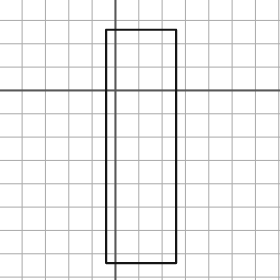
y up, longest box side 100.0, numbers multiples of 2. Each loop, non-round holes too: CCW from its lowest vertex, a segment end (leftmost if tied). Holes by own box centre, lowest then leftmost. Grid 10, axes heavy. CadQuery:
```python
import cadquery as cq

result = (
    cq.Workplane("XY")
    .moveTo(-4.0, -74.0)
    .lineTo(26.0, -74.0)
    .lineTo(26.0, 26.0)
    .lineTo(-4.0, 26.0)
    .close()
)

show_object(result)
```